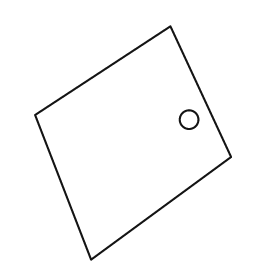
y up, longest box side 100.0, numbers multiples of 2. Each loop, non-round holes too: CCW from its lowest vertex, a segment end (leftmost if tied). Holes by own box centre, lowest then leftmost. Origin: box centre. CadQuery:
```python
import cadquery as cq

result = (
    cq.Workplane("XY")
    .moveTo(-18.0, -50.0)
    .lineTo(42.0, -6.0)
    .lineTo(16.0, 50.0)
    .lineTo(-42.0, 12.0)
    .close()
    .moveTo(24.0, 10.0)
    .circle(4.0)
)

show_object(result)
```